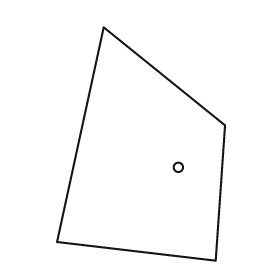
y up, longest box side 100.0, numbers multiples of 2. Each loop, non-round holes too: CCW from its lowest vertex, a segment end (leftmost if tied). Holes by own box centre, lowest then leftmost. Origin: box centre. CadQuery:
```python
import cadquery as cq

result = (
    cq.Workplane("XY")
    .moveTo(32.0, -50.0)
    .lineTo(36.0, 8.0)
    .lineTo(-16.0, 50.0)
    .lineTo(-36.0, -42.0)
    .close()
    .moveTo(16.0, -10.0)
    .circle(2.0)
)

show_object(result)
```